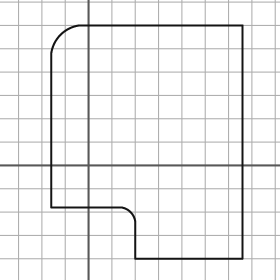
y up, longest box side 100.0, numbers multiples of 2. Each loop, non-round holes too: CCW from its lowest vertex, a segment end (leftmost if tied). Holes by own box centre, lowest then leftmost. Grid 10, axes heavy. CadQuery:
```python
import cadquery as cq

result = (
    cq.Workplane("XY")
    .moveTo(20.0, -40.0)
    .lineTo(66.0, -40.0)
    .lineTo(66.0, 60.0)
    .lineTo(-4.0, 60.0)
    .threePointArc((-12.0, 56.0), (-16.0, 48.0))
    .lineTo(-16.0, -18.0)
    .lineTo(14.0, -18.0)
    .threePointArc((18.0, -20.0), (20.0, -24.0))
    .close()
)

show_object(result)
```